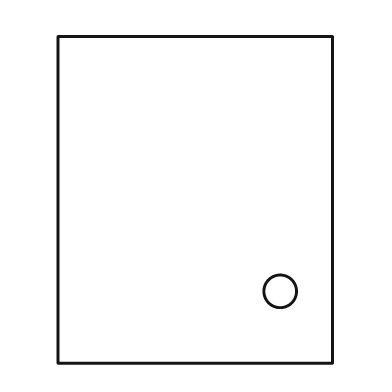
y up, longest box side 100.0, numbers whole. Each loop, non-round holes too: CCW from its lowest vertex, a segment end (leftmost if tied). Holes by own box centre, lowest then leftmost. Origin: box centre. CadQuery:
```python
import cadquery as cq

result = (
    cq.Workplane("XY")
    .moveTo(-42.0, -50.0)
    .lineTo(42.0, -50.0)
    .lineTo(42.0, 50.0)
    .lineTo(-42.0, 50.0)
    .close()
    .moveTo(26.0, -28.0)
    .circle(5.0)
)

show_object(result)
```